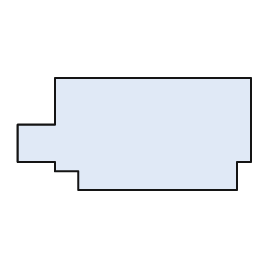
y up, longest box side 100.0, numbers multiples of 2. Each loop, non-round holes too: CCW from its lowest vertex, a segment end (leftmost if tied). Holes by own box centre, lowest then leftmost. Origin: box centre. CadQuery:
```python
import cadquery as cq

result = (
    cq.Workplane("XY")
    .moveTo(-24.0, -24.0)
    .lineTo(44.0, -24.0)
    .lineTo(44.0, -12.0)
    .lineTo(50.0, -12.0)
    .lineTo(50.0, 24.0)
    .lineTo(-34.0, 24.0)
    .lineTo(-34.0, 4.0)
    .lineTo(-50.0, 4.0)
    .lineTo(-50.0, -12.0)
    .lineTo(-34.0, -12.0)
    .lineTo(-34.0, -16.0)
    .lineTo(-24.0, -16.0)
    .close()
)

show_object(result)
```